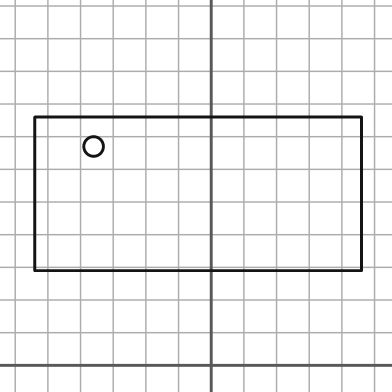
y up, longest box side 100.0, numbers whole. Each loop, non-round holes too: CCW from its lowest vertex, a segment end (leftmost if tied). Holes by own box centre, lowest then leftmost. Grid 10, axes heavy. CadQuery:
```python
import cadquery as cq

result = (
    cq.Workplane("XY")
    .moveTo(-54.0, 29.0)
    .lineTo(46.0, 29.0)
    .lineTo(46.0, 76.0)
    .lineTo(-54.0, 76.0)
    .close()
    .moveTo(-36.0, 67.0)
    .circle(3.0)
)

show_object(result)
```